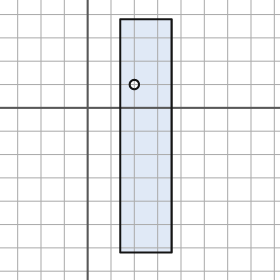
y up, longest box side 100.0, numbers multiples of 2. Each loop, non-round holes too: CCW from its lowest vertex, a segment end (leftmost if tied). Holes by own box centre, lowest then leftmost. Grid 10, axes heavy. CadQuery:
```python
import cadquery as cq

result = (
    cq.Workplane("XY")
    .moveTo(14.0, -62.0)
    .lineTo(36.0, -62.0)
    .lineTo(36.0, 38.0)
    .lineTo(14.0, 38.0)
    .close()
    .moveTo(20.0, 10.0)
    .circle(2.0)
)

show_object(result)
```